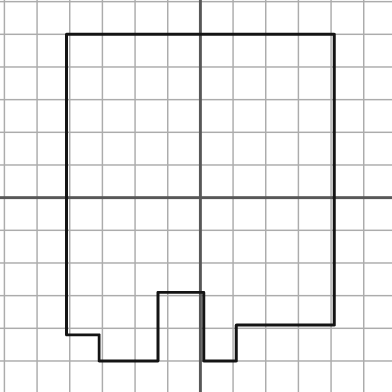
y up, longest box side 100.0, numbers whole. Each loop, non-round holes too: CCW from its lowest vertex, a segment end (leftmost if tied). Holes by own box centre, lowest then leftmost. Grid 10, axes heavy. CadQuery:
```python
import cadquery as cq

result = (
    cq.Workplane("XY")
    .moveTo(-31.0, -50.0)
    .lineTo(-13.0, -50.0)
    .lineTo(-13.0, -29.0)
    .lineTo(1.0, -29.0)
    .lineTo(1.0, -50.0)
    .lineTo(11.0, -50.0)
    .lineTo(11.0, -39.0)
    .lineTo(41.0, -39.0)
    .lineTo(41.0, 50.0)
    .lineTo(-41.0, 50.0)
    .lineTo(-41.0, -42.0)
    .lineTo(-31.0, -42.0)
    .close()
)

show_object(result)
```